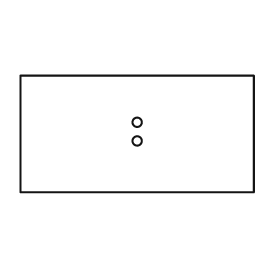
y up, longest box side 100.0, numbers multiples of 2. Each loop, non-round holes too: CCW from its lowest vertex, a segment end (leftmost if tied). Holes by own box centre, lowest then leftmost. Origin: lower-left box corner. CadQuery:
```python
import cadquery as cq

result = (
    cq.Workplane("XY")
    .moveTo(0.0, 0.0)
    .lineTo(100.0, 0.0)
    .lineTo(100.0, 50.0)
    .lineTo(0.0, 50.0)
    .close()
    .moveTo(50.0, 22.0)
    .circle(2.0)
    .moveTo(50.0, 30.0)
    .circle(2.0)
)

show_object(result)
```